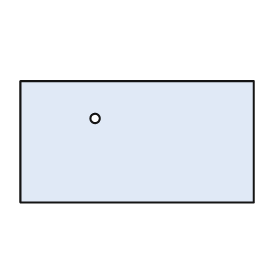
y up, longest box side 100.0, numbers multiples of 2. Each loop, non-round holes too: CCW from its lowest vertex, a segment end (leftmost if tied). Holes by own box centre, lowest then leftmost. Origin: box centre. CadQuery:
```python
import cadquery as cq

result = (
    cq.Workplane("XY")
    .moveTo(-50.0, -26.0)
    .lineTo(50.0, -26.0)
    .lineTo(50.0, 26.0)
    .lineTo(-50.0, 26.0)
    .close()
    .moveTo(-18.0, 10.0)
    .circle(2.0)
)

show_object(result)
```